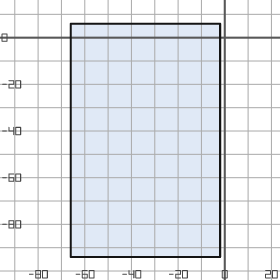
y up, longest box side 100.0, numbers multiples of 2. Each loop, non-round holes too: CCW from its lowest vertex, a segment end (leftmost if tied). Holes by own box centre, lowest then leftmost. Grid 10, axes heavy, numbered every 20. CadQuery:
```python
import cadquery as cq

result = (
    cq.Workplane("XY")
    .moveTo(-66.0, -94.0)
    .lineTo(-2.0, -94.0)
    .lineTo(-2.0, 6.0)
    .lineTo(-66.0, 6.0)
    .close()
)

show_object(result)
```